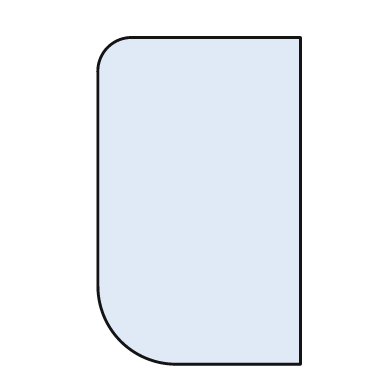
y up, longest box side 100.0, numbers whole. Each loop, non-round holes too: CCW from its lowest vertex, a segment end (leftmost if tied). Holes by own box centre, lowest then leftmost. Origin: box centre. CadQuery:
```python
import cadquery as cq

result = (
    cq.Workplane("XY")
    .moveTo(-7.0, -50.0)
    .lineTo(31.0, -50.0)
    .lineTo(31.0, 50.0)
    .lineTo(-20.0, 50.0)
    .threePointArc((-28.0, 47.0), (-31.0, 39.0))
    .lineTo(-31.0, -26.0)
    .threePointArc((-24.0, -43.0), (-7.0, -50.0))
    .close()
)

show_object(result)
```